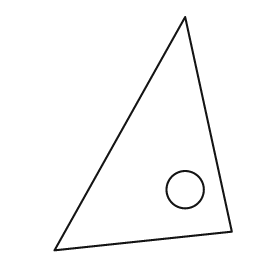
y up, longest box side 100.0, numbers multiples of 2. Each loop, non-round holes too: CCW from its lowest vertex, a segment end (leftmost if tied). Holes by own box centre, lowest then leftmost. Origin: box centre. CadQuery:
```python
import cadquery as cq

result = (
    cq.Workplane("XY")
    .moveTo(-38.0, -50.0)
    .lineTo(38.0, -42.0)
    .lineTo(18.0, 50.0)
    .close()
    .moveTo(18.0, -24.0)
    .circle(8.0)
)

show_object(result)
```